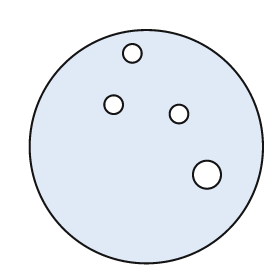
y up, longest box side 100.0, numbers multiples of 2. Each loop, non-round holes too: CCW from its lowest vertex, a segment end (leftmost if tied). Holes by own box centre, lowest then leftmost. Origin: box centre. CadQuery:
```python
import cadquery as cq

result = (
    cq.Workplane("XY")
    .moveTo(0.0, 0.0)
    .circle(50.0)
    .moveTo(26.0, -12.0)
    .circle(6.0)
    .moveTo(14.0, 14.0)
    .circle(4.0)
    .moveTo(-14.0, 18.0)
    .circle(4.0)
    .moveTo(-6.0, 40.0)
    .circle(4.0)
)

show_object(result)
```